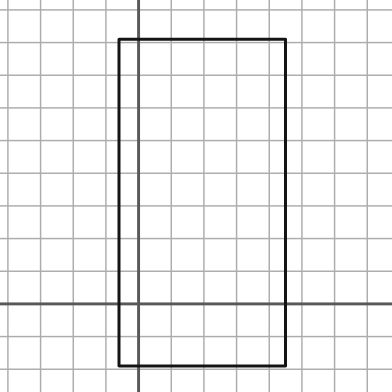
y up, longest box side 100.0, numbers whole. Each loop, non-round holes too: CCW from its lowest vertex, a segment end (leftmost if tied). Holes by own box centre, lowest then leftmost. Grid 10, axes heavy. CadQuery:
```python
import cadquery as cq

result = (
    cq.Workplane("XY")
    .moveTo(-6.0, -19.0)
    .lineTo(45.0, -19.0)
    .lineTo(45.0, 81.0)
    .lineTo(-6.0, 81.0)
    .close()
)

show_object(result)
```